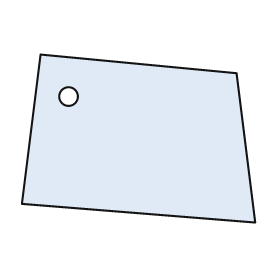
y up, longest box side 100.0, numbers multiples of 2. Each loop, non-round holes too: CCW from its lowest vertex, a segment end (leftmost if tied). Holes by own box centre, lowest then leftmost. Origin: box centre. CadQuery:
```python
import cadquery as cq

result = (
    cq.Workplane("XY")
    .moveTo(50.0, -36.0)
    .lineTo(42.0, 28.0)
    .lineTo(-42.0, 36.0)
    .lineTo(-50.0, -28.0)
    .close()
    .moveTo(-30.0, 18.0)
    .circle(4.0)
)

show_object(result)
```